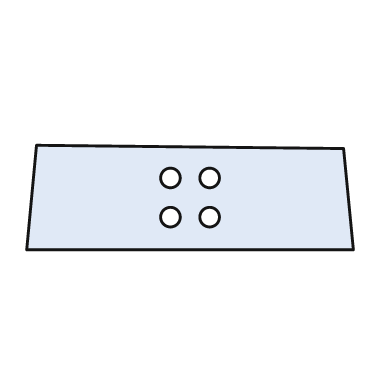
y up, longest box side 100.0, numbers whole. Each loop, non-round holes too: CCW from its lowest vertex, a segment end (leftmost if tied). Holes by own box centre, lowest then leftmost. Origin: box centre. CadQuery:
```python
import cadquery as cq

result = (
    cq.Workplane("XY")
    .moveTo(-50.0, -16.0)
    .lineTo(50.0, -16.0)
    .lineTo(47.0, 15.0)
    .lineTo(-47.0, 16.0)
    .close()
    .moveTo(-6.0, -6.0)
    .circle(3.0)
    .moveTo(6.0, -6.0)
    .circle(3.0)
    .moveTo(-6.0, 6.0)
    .circle(3.0)
    .moveTo(6.0, 6.0)
    .circle(3.0)
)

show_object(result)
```